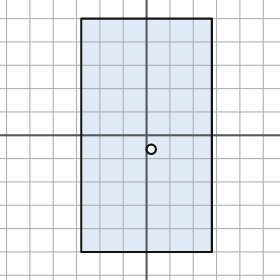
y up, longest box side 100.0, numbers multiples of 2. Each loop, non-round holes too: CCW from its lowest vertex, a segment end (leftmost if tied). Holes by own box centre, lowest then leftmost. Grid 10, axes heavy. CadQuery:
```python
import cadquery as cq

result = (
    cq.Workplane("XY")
    .moveTo(-28.0, -50.0)
    .lineTo(28.0, -50.0)
    .lineTo(28.0, 50.0)
    .lineTo(-28.0, 50.0)
    .close()
    .moveTo(2.0, -6.0)
    .circle(2.0)
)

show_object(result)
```